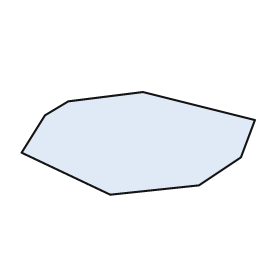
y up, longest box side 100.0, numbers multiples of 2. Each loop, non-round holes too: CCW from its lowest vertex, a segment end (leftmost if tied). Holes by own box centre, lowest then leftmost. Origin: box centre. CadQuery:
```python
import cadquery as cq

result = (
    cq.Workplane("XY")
    .moveTo(-12.0, -22.0)
    .lineTo(26.0, -18.0)
    .lineTo(44.0, -6.0)
    .lineTo(50.0, 10.0)
    .lineTo(2.0, 22.0)
    .lineTo(-30.0, 18.0)
    .lineTo(-40.0, 12.0)
    .lineTo(-50.0, -4.0)
    .close()
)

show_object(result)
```